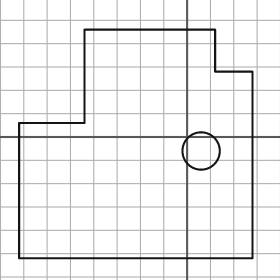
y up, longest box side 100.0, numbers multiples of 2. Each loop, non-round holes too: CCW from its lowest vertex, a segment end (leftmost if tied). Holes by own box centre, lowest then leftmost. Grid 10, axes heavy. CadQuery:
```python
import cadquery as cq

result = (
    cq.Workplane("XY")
    .moveTo(-72.0, -52.0)
    .lineTo(28.0, -52.0)
    .lineTo(28.0, 28.0)
    .lineTo(12.0, 28.0)
    .lineTo(12.0, 46.0)
    .lineTo(-44.0, 46.0)
    .lineTo(-44.0, 6.0)
    .lineTo(-72.0, 6.0)
    .close()
    .moveTo(6.0, -6.0)
    .circle(8.0)
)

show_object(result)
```